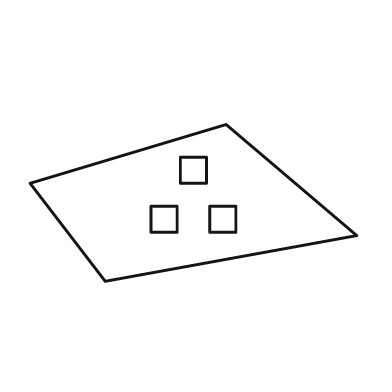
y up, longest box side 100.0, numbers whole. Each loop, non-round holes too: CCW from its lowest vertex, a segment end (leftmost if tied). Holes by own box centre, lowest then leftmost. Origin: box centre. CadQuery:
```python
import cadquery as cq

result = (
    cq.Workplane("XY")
    .moveTo(-27.0, -24.0)
    .lineTo(50.0, -10.0)
    .lineTo(10.0, 24.0)
    .lineTo(-50.0, 6.0)
    .close()
    .moveTo(-13.0, -9.0)
    .lineTo(-5.0, -9.0)
    .lineTo(-5.0, -1.0)
    .lineTo(-13.0, -1.0)
    .close()
    .moveTo(5.0, -9.0)
    .lineTo(13.0, -9.0)
    .lineTo(13.0, -1.0)
    .lineTo(5.0, -1.0)
    .close()
    .moveTo(-4.0, 6.0)
    .lineTo(4.0, 6.0)
    .lineTo(4.0, 14.0)
    .lineTo(-4.0, 14.0)
    .close()
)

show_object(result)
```